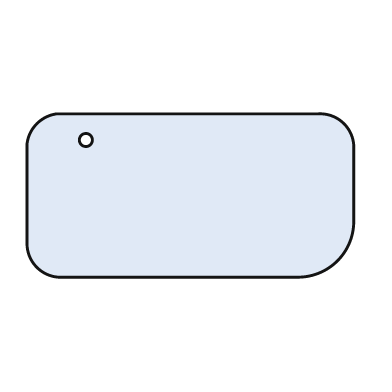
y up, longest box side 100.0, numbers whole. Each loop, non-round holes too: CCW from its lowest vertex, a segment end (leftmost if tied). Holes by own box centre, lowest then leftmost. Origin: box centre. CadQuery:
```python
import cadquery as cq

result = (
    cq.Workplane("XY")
    .moveTo(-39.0, -25.0)
    .lineTo(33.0, -25.0)
    .threePointArc((45.0, -20.0), (50.0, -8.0))
    .lineTo(50.0, 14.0)
    .threePointArc((47.0, 22.0), (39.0, 25.0))
    .lineTo(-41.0, 25.0)
    .threePointArc((-47.0, 22.0), (-50.0, 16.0))
    .lineTo(-50.0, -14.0)
    .threePointArc((-47.0, -22.0), (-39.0, -25.0))
    .close()
    .moveTo(-32.0, 17.0)
    .circle(2.0)
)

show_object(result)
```